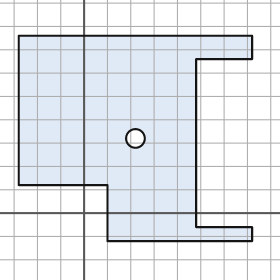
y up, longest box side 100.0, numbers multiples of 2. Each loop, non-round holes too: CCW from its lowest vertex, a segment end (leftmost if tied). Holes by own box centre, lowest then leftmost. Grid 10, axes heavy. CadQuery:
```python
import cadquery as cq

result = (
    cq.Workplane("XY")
    .moveTo(10.0, -12.0)
    .lineTo(72.0, -12.0)
    .lineTo(72.0, -6.0)
    .lineTo(48.0, -6.0)
    .lineTo(48.0, 66.0)
    .lineTo(72.0, 66.0)
    .lineTo(72.0, 76.0)
    .lineTo(-28.0, 76.0)
    .lineTo(-28.0, 12.0)
    .lineTo(10.0, 12.0)
    .close()
    .moveTo(22.0, 32.0)
    .circle(4.0)
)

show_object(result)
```